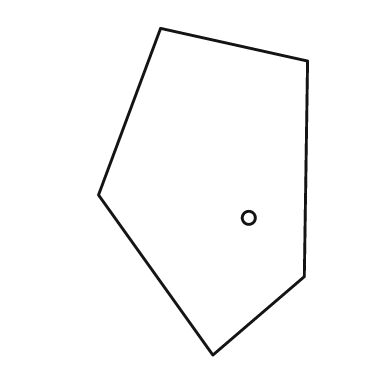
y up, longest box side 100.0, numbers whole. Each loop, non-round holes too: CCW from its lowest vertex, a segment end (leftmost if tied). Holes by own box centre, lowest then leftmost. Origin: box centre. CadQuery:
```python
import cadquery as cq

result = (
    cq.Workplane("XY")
    .moveTo(3.0, -50.0)
    .lineTo(31.0, -26.0)
    .lineTo(32.0, 40.0)
    .lineTo(-13.0, 50.0)
    .lineTo(-32.0, -1.0)
    .close()
    .moveTo(14.0, -8.0)
    .circle(2.0)
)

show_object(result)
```